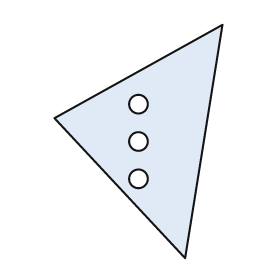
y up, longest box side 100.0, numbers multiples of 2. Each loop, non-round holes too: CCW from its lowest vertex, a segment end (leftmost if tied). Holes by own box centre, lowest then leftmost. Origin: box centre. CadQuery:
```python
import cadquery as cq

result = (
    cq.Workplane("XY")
    .moveTo(20.0, -50.0)
    .lineTo(36.0, 50.0)
    .lineTo(-36.0, 10.0)
    .close()
    .moveTo(0.0, -16.0)
    .circle(4.0)
    .moveTo(0.0, 0.0)
    .circle(4.0)
    .moveTo(0.0, 16.0)
    .circle(4.0)
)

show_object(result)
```